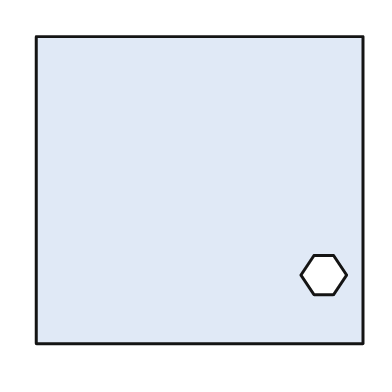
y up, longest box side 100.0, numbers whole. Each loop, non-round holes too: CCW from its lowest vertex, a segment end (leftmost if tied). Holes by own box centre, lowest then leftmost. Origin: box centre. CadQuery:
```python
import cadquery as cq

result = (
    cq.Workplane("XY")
    .moveTo(-50.0, -47.0)
    .lineTo(50.0, -47.0)
    .lineTo(50.0, 47.0)
    .lineTo(-50.0, 47.0)
    .close()
    .moveTo(35.0, -32.0)
    .lineTo(41.0, -32.0)
    .lineTo(45.0, -26.0)
    .lineTo(41.0, -20.0)
    .lineTo(35.0, -20.0)
    .lineTo(31.0, -26.0)
    .close()
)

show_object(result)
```